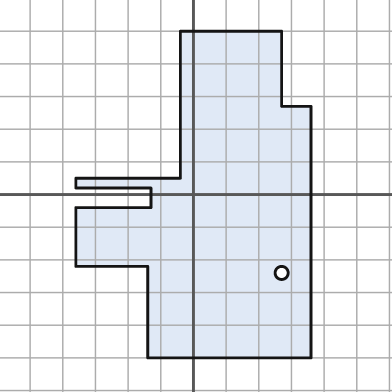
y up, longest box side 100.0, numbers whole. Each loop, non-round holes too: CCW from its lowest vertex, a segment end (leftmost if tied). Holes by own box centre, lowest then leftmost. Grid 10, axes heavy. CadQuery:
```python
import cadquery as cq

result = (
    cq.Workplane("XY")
    .moveTo(-14.0, -50.0)
    .lineTo(36.0, -50.0)
    .lineTo(36.0, 27.0)
    .lineTo(27.0, 27.0)
    .lineTo(27.0, 50.0)
    .lineTo(-4.0, 50.0)
    .lineTo(-4.0, 5.0)
    .lineTo(-36.0, 5.0)
    .lineTo(-36.0, 2.0)
    .lineTo(-13.0, 2.0)
    .lineTo(-13.0, -4.0)
    .lineTo(-36.0, -4.0)
    .lineTo(-36.0, -22.0)
    .lineTo(-14.0, -22.0)
    .close()
    .moveTo(27.0, -24.0)
    .circle(2.0)
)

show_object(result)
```